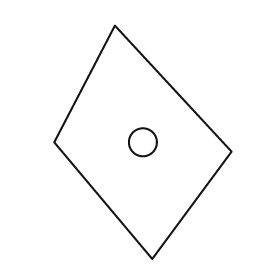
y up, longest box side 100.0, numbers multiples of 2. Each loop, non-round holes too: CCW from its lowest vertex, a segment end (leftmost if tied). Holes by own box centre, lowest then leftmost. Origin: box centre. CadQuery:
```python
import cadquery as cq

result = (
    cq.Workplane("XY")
    .moveTo(4.0, -50.0)
    .lineTo(38.0, -4.0)
    .lineTo(-12.0, 50.0)
    .lineTo(-38.0, 0.0)
    .close()
    .moveTo(0.0, 0.0)
    .circle(6.0)
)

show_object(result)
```